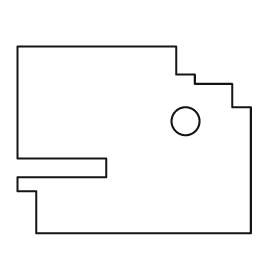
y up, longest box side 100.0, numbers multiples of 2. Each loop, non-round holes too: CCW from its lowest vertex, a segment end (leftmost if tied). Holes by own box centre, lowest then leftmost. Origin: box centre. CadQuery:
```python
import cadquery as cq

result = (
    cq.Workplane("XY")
    .moveTo(-42.0, -40.0)
    .lineTo(50.0, -40.0)
    .lineTo(50.0, 14.0)
    .lineTo(42.0, 14.0)
    .lineTo(42.0, 24.0)
    .lineTo(26.0, 24.0)
    .lineTo(26.0, 28.0)
    .lineTo(18.0, 28.0)
    .lineTo(18.0, 40.0)
    .lineTo(-50.0, 40.0)
    .lineTo(-50.0, -8.0)
    .lineTo(-12.0, -8.0)
    .lineTo(-12.0, -16.0)
    .lineTo(-50.0, -16.0)
    .lineTo(-50.0, -22.0)
    .lineTo(-42.0, -22.0)
    .close()
    .moveTo(22.0, 8.0)
    .circle(6.0)
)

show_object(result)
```